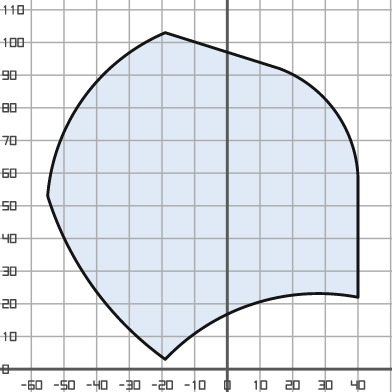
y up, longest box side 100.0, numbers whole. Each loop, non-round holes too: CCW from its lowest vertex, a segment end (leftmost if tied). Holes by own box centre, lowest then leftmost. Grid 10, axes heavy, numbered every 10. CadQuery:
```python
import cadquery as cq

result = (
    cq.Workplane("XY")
    .moveTo(-19.0, 3.0)
    .threePointArc((8.0, 20.0), (40.0, 22.0))
    .lineTo(40.0, 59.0)
    .threePointArc((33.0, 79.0), (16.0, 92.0))
    .lineTo(-19.0, 103.0)
    .threePointArc((-44.0, 83.0), (-55.0, 53.0))
    .threePointArc((-41.0, 25.0), (-19.0, 3.0))
    .close()
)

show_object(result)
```